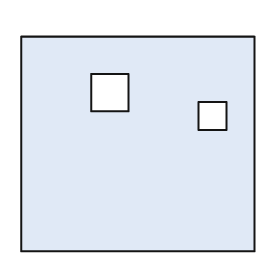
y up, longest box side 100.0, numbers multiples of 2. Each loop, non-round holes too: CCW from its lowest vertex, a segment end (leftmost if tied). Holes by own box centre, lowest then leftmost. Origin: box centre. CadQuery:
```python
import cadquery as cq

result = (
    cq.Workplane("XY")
    .moveTo(-50.0, -46.0)
    .lineTo(50.0, -46.0)
    .lineTo(50.0, 46.0)
    .lineTo(-50.0, 46.0)
    .close()
    .moveTo(26.0, 6.0)
    .lineTo(38.0, 6.0)
    .lineTo(38.0, 18.0)
    .lineTo(26.0, 18.0)
    .close()
    .moveTo(-20.0, 14.0)
    .lineTo(-4.0, 14.0)
    .lineTo(-4.0, 30.0)
    .lineTo(-20.0, 30.0)
    .close()
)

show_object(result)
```